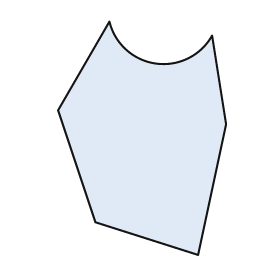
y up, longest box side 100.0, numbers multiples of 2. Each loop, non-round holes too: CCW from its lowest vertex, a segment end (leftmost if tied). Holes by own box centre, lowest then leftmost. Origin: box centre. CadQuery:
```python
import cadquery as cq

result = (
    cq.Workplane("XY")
    .moveTo(24.0, -50.0)
    .lineTo(36.0, 6.0)
    .lineTo(30.0, 44.0)
    .threePointArc((6.0, 32.0), (-14.0, 50.0))
    .lineTo(-36.0, 12.0)
    .lineTo(-20.0, -36.0)
    .close()
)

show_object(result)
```